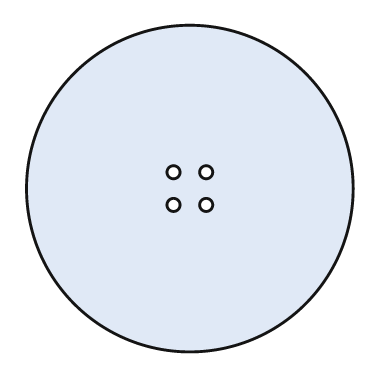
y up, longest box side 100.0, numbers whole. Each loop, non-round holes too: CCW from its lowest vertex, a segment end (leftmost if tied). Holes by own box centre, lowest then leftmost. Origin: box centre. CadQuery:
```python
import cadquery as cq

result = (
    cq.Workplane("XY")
    .moveTo(0.0, 0.0)
    .circle(50.0)
    .moveTo(-5.0, -5.0)
    .circle(2.0)
    .moveTo(5.0, -5.0)
    .circle(2.0)
    .moveTo(-5.0, 5.0)
    .circle(2.0)
    .moveTo(5.0, 5.0)
    .circle(2.0)
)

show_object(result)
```